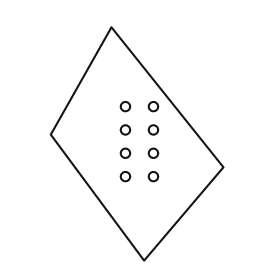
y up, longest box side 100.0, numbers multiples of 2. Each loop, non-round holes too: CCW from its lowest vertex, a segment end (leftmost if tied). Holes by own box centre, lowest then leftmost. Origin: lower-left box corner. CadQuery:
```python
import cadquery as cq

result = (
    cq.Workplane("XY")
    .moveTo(40.0, 0.0)
    .lineTo(74.0, 40.0)
    .lineTo(26.0, 100.0)
    .lineTo(0.0, 54.0)
    .close()
    .moveTo(32.0, 36.0)
    .circle(2.0)
    .moveTo(44.0, 36.0)
    .circle(2.0)
    .moveTo(32.0, 46.0)
    .circle(2.0)
    .moveTo(44.0, 46.0)
    .circle(2.0)
    .moveTo(32.0, 56.0)
    .circle(2.0)
    .moveTo(44.0, 56.0)
    .circle(2.0)
    .moveTo(32.0, 66.0)
    .circle(2.0)
    .moveTo(44.0, 66.0)
    .circle(2.0)
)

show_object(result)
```